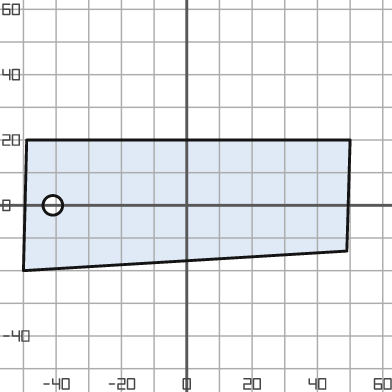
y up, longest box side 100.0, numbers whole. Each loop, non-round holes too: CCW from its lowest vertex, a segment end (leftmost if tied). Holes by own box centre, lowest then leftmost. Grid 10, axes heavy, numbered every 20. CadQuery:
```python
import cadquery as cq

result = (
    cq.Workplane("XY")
    .moveTo(-50.0, -20.0)
    .lineTo(49.0, -14.0)
    .lineTo(50.0, 20.0)
    .lineTo(-49.0, 20.0)
    .close()
    .moveTo(-41.0, 0.0)
    .circle(3.0)
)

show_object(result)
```